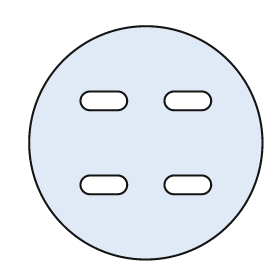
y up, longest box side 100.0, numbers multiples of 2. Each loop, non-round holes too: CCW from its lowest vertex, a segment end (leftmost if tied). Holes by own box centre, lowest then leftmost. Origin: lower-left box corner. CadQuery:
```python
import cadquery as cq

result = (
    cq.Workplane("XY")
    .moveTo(50.0, 50.0)
    .circle(50.0)
    .moveTo(26.0, 28.0)
    .lineTo(38.0, 28.0)
    .threePointArc((42.0, 32.0), (38.0, 36.0))
    .lineTo(26.0, 36.0)
    .threePointArc((22.0, 32.0), (26.0, 28.0))
    .close()
    .moveTo(62.0, 28.0)
    .lineTo(74.0, 28.0)
    .threePointArc((78.0, 32.0), (74.0, 36.0))
    .lineTo(62.0, 36.0)
    .threePointArc((58.0, 32.0), (62.0, 28.0))
    .close()
    .moveTo(26.0, 64.0)
    .lineTo(38.0, 64.0)
    .threePointArc((42.0, 68.0), (38.0, 72.0))
    .lineTo(26.0, 72.0)
    .threePointArc((22.0, 68.0), (26.0, 64.0))
    .close()
    .moveTo(62.0, 64.0)
    .lineTo(74.0, 64.0)
    .threePointArc((78.0, 68.0), (74.0, 72.0))
    .lineTo(62.0, 72.0)
    .threePointArc((58.0, 68.0), (62.0, 64.0))
    .close()
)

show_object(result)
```